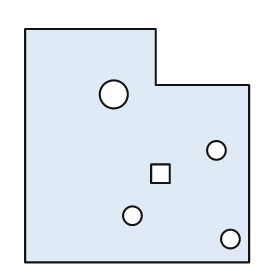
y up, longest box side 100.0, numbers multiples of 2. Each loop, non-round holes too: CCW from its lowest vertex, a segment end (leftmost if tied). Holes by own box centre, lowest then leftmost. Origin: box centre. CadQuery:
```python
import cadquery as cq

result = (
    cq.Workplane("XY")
    .moveTo(-48.0, -50.0)
    .lineTo(48.0, -50.0)
    .lineTo(48.0, 26.0)
    .lineTo(8.0, 26.0)
    .lineTo(8.0, 50.0)
    .lineTo(-48.0, 50.0)
    .close()
    .moveTo(40.0, -40.0)
    .circle(4.0)
    .moveTo(-2.0, -30.0)
    .circle(4.0)
    .moveTo(6.0, -16.0)
    .lineTo(14.0, -16.0)
    .lineTo(14.0, -8.0)
    .lineTo(6.0, -8.0)
    .close()
    .moveTo(34.0, -2.0)
    .circle(4.0)
    .moveTo(-10.0, 22.0)
    .circle(6.0)
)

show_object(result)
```